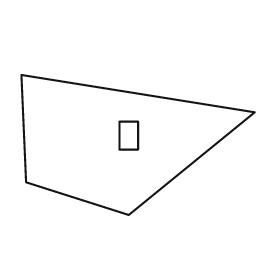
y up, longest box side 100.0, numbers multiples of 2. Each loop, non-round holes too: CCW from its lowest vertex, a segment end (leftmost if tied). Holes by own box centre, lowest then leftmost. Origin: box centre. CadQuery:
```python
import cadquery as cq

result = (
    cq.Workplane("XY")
    .moveTo(-4.0, -30.0)
    .lineTo(50.0, 14.0)
    .lineTo(-50.0, 30.0)
    .lineTo(-48.0, -16.0)
    .close()
    .moveTo(-8.0, -2.0)
    .lineTo(0.0, -2.0)
    .lineTo(0.0, 10.0)
    .lineTo(-8.0, 10.0)
    .close()
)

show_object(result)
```